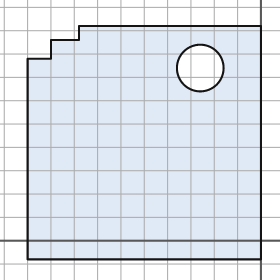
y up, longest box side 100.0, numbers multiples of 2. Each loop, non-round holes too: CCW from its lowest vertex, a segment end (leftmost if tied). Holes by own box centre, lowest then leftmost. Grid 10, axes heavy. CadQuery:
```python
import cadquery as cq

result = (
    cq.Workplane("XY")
    .moveTo(-100.0, -8.0)
    .lineTo(0.0, -8.0)
    .lineTo(0.0, 92.0)
    .lineTo(-78.0, 92.0)
    .lineTo(-78.0, 86.0)
    .lineTo(-90.0, 86.0)
    .lineTo(-90.0, 78.0)
    .lineTo(-100.0, 78.0)
    .close()
    .moveTo(-26.0, 74.0)
    .circle(10.0)
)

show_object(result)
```